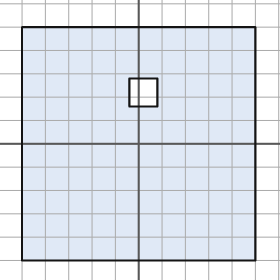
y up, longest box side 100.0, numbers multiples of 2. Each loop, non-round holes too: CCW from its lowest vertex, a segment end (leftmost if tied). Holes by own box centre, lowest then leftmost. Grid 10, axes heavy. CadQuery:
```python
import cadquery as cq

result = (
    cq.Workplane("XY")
    .moveTo(-50.0, -50.0)
    .lineTo(50.0, -50.0)
    .lineTo(50.0, 50.0)
    .lineTo(-50.0, 50.0)
    .close()
    .moveTo(-4.0, 16.0)
    .lineTo(8.0, 16.0)
    .lineTo(8.0, 28.0)
    .lineTo(-4.0, 28.0)
    .close()
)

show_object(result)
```